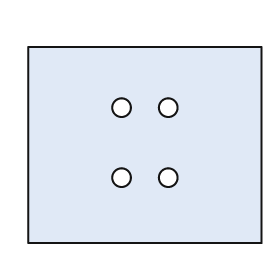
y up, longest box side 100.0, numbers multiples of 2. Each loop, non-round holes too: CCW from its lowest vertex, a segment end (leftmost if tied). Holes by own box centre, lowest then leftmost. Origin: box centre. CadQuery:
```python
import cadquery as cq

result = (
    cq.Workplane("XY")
    .moveTo(-50.0, -42.0)
    .lineTo(50.0, -42.0)
    .lineTo(50.0, 42.0)
    .lineTo(-50.0, 42.0)
    .close()
    .moveTo(-10.0, -14.0)
    .circle(4.0)
    .moveTo(10.0, -14.0)
    .circle(4.0)
    .moveTo(-10.0, 16.0)
    .circle(4.0)
    .moveTo(10.0, 16.0)
    .circle(4.0)
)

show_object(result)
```